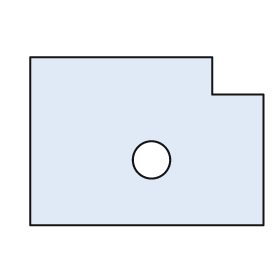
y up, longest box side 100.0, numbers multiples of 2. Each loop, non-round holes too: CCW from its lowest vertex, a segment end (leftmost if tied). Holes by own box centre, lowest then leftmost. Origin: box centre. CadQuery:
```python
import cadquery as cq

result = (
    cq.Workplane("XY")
    .moveTo(-50.0, -36.0)
    .lineTo(50.0, -36.0)
    .lineTo(50.0, 20.0)
    .lineTo(28.0, 20.0)
    .lineTo(28.0, 36.0)
    .lineTo(-50.0, 36.0)
    .close()
    .moveTo(2.0, -8.0)
    .circle(8.0)
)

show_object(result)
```